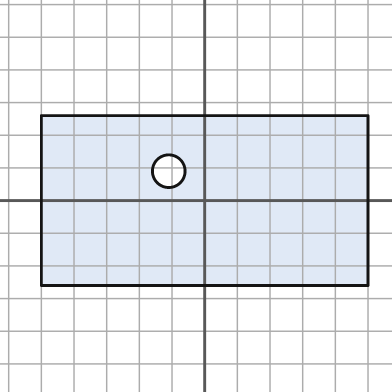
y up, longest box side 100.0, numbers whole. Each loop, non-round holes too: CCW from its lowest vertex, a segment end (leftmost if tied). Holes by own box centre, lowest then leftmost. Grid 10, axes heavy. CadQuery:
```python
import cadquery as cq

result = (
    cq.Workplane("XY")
    .moveTo(-50.0, -26.0)
    .lineTo(50.0, -26.0)
    .lineTo(50.0, 26.0)
    .lineTo(-50.0, 26.0)
    .close()
    .moveTo(-11.0, 9.0)
    .circle(5.0)
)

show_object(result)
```